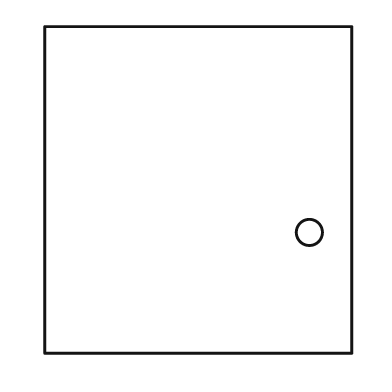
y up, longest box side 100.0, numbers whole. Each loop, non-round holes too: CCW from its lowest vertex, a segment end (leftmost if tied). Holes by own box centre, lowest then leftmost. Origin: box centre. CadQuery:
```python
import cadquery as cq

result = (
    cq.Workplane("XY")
    .moveTo(-47.0, -50.0)
    .lineTo(47.0, -50.0)
    .lineTo(47.0, 50.0)
    .lineTo(-47.0, 50.0)
    .close()
    .moveTo(34.0, -13.0)
    .circle(4.0)
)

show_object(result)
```